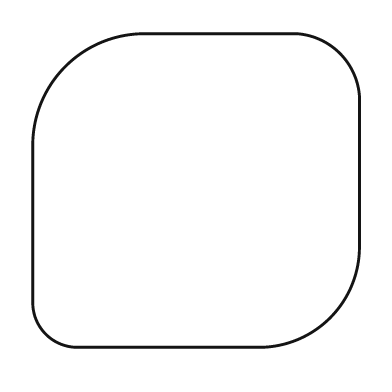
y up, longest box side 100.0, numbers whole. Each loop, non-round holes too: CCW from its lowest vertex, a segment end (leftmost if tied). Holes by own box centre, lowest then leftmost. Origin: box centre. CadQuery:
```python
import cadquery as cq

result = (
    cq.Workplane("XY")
    .moveTo(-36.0, -48.0)
    .lineTo(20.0, -48.0)
    .threePointArc((41.0, -39.0), (50.0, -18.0))
    .lineTo(50.0, 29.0)
    .threePointArc((44.0, 42.0), (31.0, 48.0))
    .lineTo(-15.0, 48.0)
    .threePointArc((-40.0, 38.0), (-50.0, 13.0))
    .lineTo(-50.0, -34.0)
    .threePointArc((-46.0, -44.0), (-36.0, -48.0))
    .close()
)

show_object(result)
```